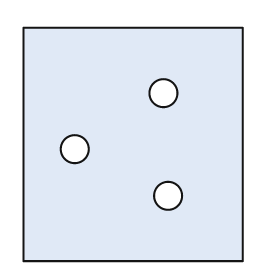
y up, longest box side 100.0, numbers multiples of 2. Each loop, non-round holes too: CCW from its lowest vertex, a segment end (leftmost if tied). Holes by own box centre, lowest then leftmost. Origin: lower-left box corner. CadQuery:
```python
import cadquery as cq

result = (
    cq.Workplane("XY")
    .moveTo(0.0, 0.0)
    .lineTo(94.0, 0.0)
    .lineTo(94.0, 100.0)
    .lineTo(0.0, 100.0)
    .close()
    .moveTo(62.0, 28.0)
    .circle(6.0)
    .moveTo(22.0, 48.0)
    .circle(6.0)
    .moveTo(60.0, 72.0)
    .circle(6.0)
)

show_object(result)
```